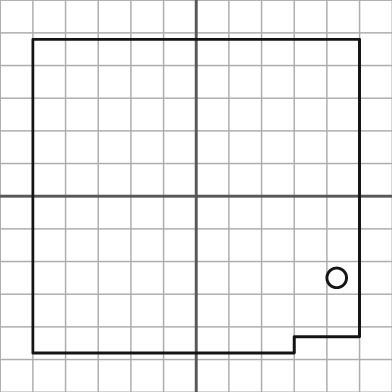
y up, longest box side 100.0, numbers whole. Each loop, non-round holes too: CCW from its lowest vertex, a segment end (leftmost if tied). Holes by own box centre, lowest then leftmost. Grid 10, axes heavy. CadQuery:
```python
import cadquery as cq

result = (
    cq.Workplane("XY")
    .moveTo(-50.0, -48.0)
    .lineTo(30.0, -48.0)
    .lineTo(30.0, -43.0)
    .lineTo(50.0, -43.0)
    .lineTo(50.0, 48.0)
    .lineTo(-50.0, 48.0)
    .close()
    .moveTo(43.0, -25.0)
    .circle(3.0)
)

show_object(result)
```